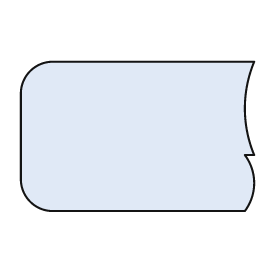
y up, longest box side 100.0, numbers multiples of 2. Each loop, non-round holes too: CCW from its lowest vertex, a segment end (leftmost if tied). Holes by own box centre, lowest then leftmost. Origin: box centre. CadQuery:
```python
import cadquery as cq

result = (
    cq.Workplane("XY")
    .moveTo(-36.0, -32.0)
    .lineTo(46.0, -32.0)
    .threePointArc((50.0, -20.0), (46.0, -8.0))
    .lineTo(50.0, -8.0)
    .threePointArc((46.0, 12.0), (50.0, 32.0))
    .lineTo(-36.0, 32.0)
    .threePointArc((-46.0, 28.0), (-50.0, 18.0))
    .lineTo(-50.0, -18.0)
    .threePointArc((-46.0, -28.0), (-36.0, -32.0))
    .close()
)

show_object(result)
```